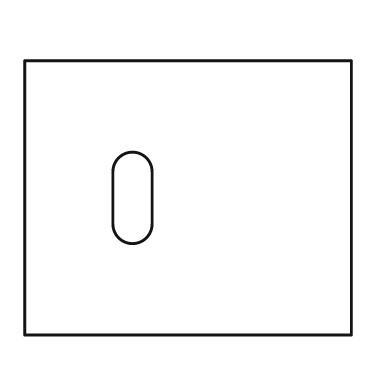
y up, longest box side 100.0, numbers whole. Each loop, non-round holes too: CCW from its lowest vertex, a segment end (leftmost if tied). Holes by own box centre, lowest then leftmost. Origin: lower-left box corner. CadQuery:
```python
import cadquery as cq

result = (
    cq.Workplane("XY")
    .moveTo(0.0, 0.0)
    .lineTo(100.0, 0.0)
    .lineTo(100.0, 84.0)
    .lineTo(0.0, 84.0)
    .close()
    .moveTo(27.0, 34.0)
    .threePointArc((33.0, 28.0), (39.0, 34.0))
    .lineTo(39.0, 50.0)
    .threePointArc((33.0, 56.0), (27.0, 50.0))
    .close()
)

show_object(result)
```